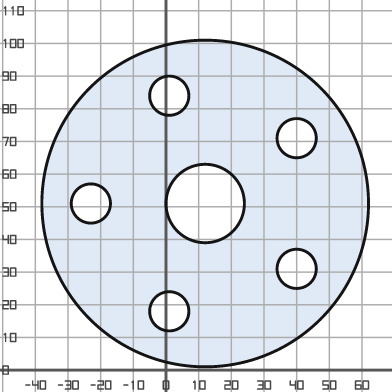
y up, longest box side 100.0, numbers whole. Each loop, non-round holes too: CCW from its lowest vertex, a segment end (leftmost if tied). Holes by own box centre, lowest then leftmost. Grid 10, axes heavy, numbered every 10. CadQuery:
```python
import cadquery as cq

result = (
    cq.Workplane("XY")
    .moveTo(12.0, 51.0)
    .circle(50.0)
    .moveTo(1.0, 18.0)
    .circle(6.0)
    .moveTo(40.0, 31.0)
    .circle(6.0)
    .moveTo(-23.0, 51.0)
    .circle(6.0)
    .moveTo(12.0, 51.0)
    .circle(12.0)
    .moveTo(40.0, 71.0)
    .circle(6.0)
    .moveTo(1.0, 84.0)
    .circle(6.0)
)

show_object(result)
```